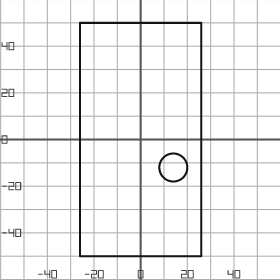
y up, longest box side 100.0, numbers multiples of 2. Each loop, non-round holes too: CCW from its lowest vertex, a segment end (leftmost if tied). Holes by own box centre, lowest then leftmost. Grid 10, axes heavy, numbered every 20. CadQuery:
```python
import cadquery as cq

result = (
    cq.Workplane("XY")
    .moveTo(-26.0, -50.0)
    .lineTo(26.0, -50.0)
    .lineTo(26.0, 50.0)
    .lineTo(-26.0, 50.0)
    .close()
    .moveTo(14.0, -12.0)
    .circle(6.0)
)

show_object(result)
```